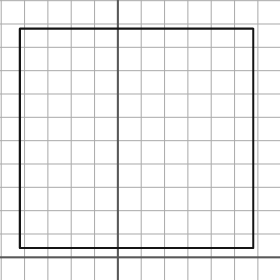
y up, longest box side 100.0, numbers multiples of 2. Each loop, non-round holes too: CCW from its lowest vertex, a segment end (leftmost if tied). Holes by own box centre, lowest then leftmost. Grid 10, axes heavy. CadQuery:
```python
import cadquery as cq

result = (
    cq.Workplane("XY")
    .moveTo(-42.0, 4.0)
    .lineTo(58.0, 4.0)
    .lineTo(58.0, 98.0)
    .lineTo(-42.0, 98.0)
    .close()
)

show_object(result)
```